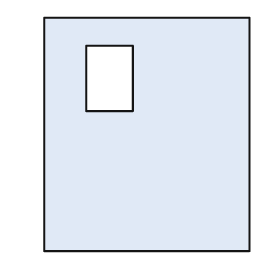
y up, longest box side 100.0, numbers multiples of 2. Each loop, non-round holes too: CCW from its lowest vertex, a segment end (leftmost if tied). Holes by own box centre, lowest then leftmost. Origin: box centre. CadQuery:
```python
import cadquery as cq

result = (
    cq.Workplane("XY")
    .moveTo(-44.0, -50.0)
    .lineTo(44.0, -50.0)
    .lineTo(44.0, 50.0)
    .lineTo(-44.0, 50.0)
    .close()
    .moveTo(-26.0, 10.0)
    .lineTo(-6.0, 10.0)
    .lineTo(-6.0, 38.0)
    .lineTo(-26.0, 38.0)
    .close()
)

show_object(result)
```